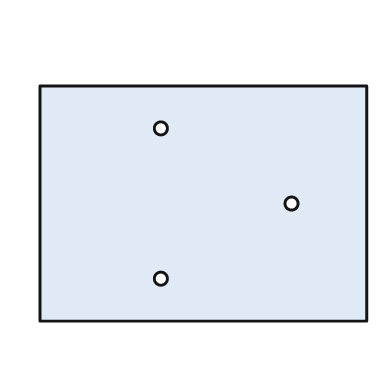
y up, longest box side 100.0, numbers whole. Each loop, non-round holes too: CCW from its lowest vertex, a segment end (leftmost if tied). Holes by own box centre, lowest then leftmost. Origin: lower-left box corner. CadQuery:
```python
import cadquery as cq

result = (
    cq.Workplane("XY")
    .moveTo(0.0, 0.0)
    .lineTo(100.0, 0.0)
    .lineTo(100.0, 72.0)
    .lineTo(0.0, 72.0)
    .close()
    .moveTo(37.0, 13.0)
    .circle(2.0)
    .moveTo(77.0, 36.0)
    .circle(2.0)
    .moveTo(37.0, 59.0)
    .circle(2.0)
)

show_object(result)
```